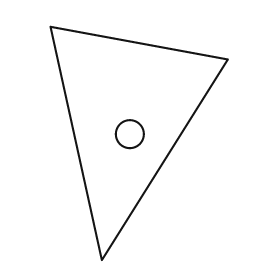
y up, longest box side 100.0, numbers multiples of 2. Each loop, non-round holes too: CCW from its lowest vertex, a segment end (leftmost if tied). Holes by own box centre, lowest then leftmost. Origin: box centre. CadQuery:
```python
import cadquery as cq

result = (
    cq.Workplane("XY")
    .moveTo(-16.0, -50.0)
    .lineTo(38.0, 36.0)
    .lineTo(-38.0, 50.0)
    .close()
    .moveTo(-4.0, 4.0)
    .circle(6.0)
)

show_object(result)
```